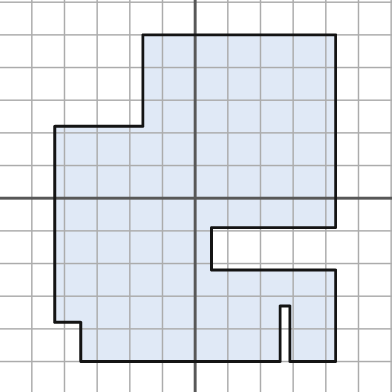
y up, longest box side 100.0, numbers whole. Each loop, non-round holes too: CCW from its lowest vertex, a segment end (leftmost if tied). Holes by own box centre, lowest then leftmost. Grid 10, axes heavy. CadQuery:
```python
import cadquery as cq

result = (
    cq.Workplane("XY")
    .moveTo(-35.0, -50.0)
    .lineTo(26.0, -50.0)
    .lineTo(26.0, -33.0)
    .lineTo(29.0, -33.0)
    .lineTo(29.0, -50.0)
    .lineTo(43.0, -50.0)
    .lineTo(43.0, -22.0)
    .lineTo(5.0, -22.0)
    .lineTo(5.0, -9.0)
    .lineTo(43.0, -9.0)
    .lineTo(43.0, 50.0)
    .lineTo(-16.0, 50.0)
    .lineTo(-16.0, 22.0)
    .lineTo(-43.0, 22.0)
    .lineTo(-43.0, -38.0)
    .lineTo(-35.0, -38.0)
    .close()
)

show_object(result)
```